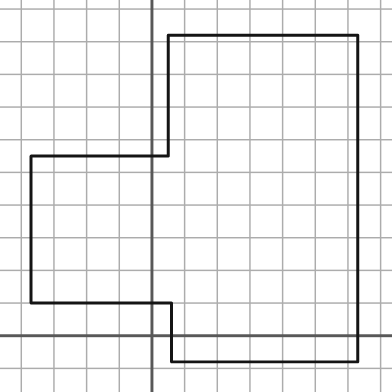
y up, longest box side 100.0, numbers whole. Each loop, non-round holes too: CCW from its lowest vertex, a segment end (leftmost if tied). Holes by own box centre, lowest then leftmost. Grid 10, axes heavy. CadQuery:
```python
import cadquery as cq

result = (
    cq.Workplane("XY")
    .moveTo(6.0, -8.0)
    .lineTo(63.0, -8.0)
    .lineTo(63.0, 92.0)
    .lineTo(5.0, 92.0)
    .lineTo(5.0, 55.0)
    .lineTo(-37.0, 55.0)
    .lineTo(-37.0, 10.0)
    .lineTo(6.0, 10.0)
    .close()
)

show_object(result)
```